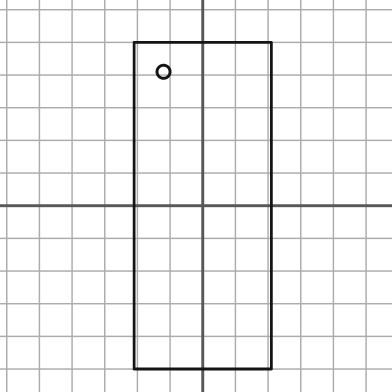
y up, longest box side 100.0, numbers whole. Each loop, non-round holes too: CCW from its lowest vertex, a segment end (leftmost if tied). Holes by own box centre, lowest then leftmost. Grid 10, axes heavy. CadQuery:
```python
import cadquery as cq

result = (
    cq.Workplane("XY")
    .moveTo(-21.0, -50.0)
    .lineTo(21.0, -50.0)
    .lineTo(21.0, 50.0)
    .lineTo(-21.0, 50.0)
    .close()
    .moveTo(-12.0, 41.0)
    .circle(2.0)
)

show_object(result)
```